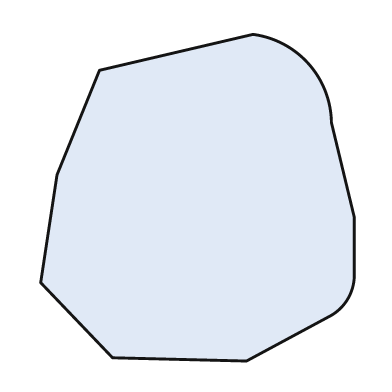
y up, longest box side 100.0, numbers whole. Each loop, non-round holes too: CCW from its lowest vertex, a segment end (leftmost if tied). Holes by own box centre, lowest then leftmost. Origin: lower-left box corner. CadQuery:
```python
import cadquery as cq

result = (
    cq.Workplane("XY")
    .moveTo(63.0, 0.0)
    .lineTo(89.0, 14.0)
    .threePointArc((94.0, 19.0), (96.0, 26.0))
    .lineTo(96.0, 44.0)
    .lineTo(89.0, 73.0)
    .threePointArc((82.0, 91.0), (65.0, 100.0))
    .lineTo(18.0, 89.0)
    .lineTo(5.0, 57.0)
    .lineTo(0.0, 24.0)
    .lineTo(22.0, 1.0)
    .close()
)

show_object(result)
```